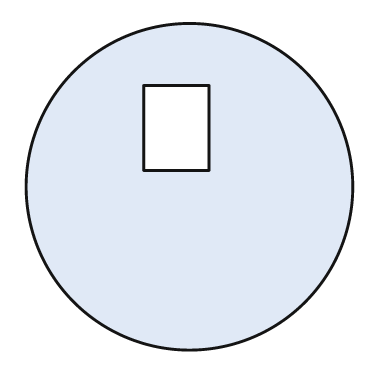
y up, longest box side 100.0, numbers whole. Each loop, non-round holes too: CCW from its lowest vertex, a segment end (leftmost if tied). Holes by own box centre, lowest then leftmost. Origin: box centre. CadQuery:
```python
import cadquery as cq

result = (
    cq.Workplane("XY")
    .moveTo(0.0, 0.0)
    .circle(50.0)
    .moveTo(-14.0, 5.0)
    .lineTo(6.0, 5.0)
    .lineTo(6.0, 31.0)
    .lineTo(-14.0, 31.0)
    .close()
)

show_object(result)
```